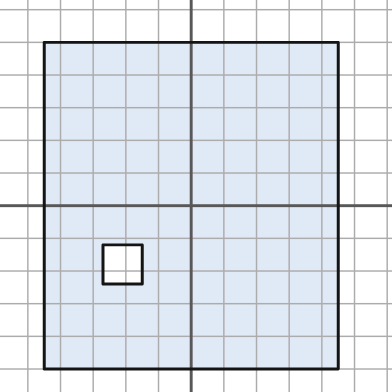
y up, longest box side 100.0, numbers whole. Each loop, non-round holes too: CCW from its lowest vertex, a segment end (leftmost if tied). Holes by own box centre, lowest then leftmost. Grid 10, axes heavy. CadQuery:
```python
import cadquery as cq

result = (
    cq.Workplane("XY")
    .moveTo(-45.0, -50.0)
    .lineTo(45.0, -50.0)
    .lineTo(45.0, 50.0)
    .lineTo(-45.0, 50.0)
    .close()
    .moveTo(-27.0, -24.0)
    .lineTo(-15.0, -24.0)
    .lineTo(-15.0, -12.0)
    .lineTo(-27.0, -12.0)
    .close()
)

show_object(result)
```